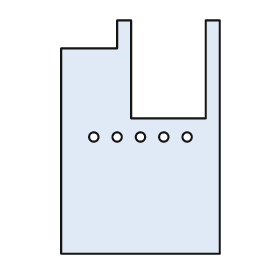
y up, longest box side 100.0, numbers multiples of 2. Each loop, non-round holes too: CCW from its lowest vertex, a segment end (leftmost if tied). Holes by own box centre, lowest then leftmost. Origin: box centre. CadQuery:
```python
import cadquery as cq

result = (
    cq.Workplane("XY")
    .moveTo(-34.0, -50.0)
    .lineTo(34.0, -50.0)
    .lineTo(34.0, 50.0)
    .lineTo(28.0, 50.0)
    .lineTo(28.0, 8.0)
    .lineTo(-4.0, 8.0)
    .lineTo(-4.0, 50.0)
    .lineTo(-10.0, 50.0)
    .lineTo(-10.0, 38.0)
    .lineTo(-34.0, 38.0)
    .close()
    .moveTo(-20.0, 0.0)
    .circle(2.0)
    .moveTo(-10.0, 0.0)
    .circle(2.0)
    .moveTo(0.0, 0.0)
    .circle(2.0)
    .moveTo(10.0, 0.0)
    .circle(2.0)
    .moveTo(20.0, 0.0)
    .circle(2.0)
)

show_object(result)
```